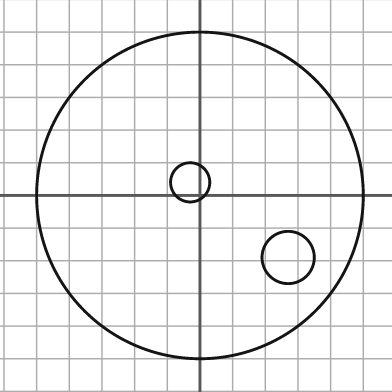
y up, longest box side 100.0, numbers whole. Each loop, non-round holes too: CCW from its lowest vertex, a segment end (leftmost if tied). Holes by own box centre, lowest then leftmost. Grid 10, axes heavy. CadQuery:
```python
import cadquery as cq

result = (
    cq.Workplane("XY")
    .moveTo(0.0, 0.0)
    .circle(50.0)
    .moveTo(27.0, -19.0)
    .circle(8.0)
    .moveTo(-3.0, 4.0)
    .circle(6.0)
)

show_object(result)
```